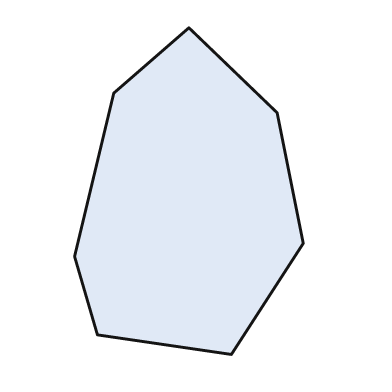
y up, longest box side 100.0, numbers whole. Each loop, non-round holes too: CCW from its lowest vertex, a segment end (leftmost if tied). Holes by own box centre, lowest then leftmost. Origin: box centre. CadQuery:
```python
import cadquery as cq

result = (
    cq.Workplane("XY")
    .moveTo(13.0, -50.0)
    .lineTo(35.0, -16.0)
    .lineTo(27.0, 24.0)
    .lineTo(0.0, 50.0)
    .lineTo(-23.0, 30.0)
    .lineTo(-35.0, -20.0)
    .lineTo(-28.0, -44.0)
    .close()
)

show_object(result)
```